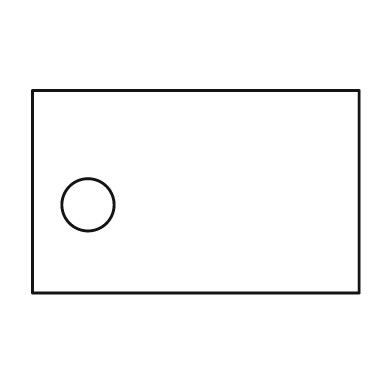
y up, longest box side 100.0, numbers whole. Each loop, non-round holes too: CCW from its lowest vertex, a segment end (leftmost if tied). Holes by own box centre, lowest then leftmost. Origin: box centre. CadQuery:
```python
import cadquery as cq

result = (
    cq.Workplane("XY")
    .moveTo(-50.0, -31.0)
    .lineTo(50.0, -31.0)
    .lineTo(50.0, 31.0)
    .lineTo(-50.0, 31.0)
    .close()
    .moveTo(-33.0, -4.0)
    .circle(8.0)
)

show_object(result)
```